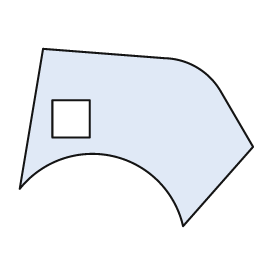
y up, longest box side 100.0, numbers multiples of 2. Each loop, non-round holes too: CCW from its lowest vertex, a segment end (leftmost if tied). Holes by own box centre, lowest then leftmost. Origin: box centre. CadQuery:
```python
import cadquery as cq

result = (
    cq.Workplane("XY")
    .moveTo(20.0, -38.0)
    .lineTo(50.0, -4.0)
    .lineTo(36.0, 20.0)
    .threePointArc((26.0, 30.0), (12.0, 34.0))
    .lineTo(-40.0, 38.0)
    .lineTo(-50.0, -22.0)
    .threePointArc((-10.0, -8.0), (20.0, -38.0))
    .close()
    .moveTo(-36.0, 0.0)
    .lineTo(-20.0, 0.0)
    .lineTo(-20.0, 16.0)
    .lineTo(-36.0, 16.0)
    .close()
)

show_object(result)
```